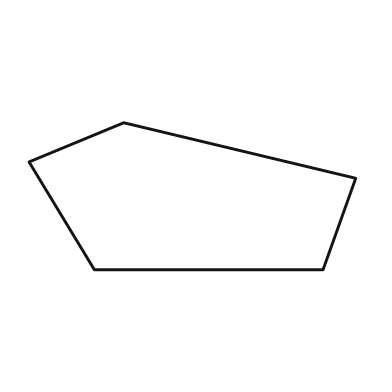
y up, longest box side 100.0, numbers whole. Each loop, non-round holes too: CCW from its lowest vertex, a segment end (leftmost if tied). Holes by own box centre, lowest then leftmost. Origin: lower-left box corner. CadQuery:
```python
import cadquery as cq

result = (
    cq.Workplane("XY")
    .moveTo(20.0, 0.0)
    .lineTo(90.0, 0.0)
    .lineTo(100.0, 28.0)
    .lineTo(29.0, 45.0)
    .lineTo(0.0, 33.0)
    .close()
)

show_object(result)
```